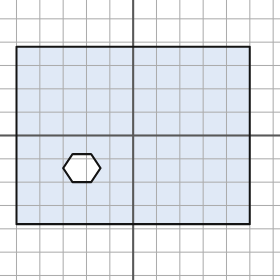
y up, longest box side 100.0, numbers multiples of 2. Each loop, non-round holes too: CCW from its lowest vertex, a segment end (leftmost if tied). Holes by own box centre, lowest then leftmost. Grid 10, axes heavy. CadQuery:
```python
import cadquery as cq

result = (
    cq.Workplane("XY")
    .moveTo(-50.0, -38.0)
    .lineTo(50.0, -38.0)
    .lineTo(50.0, 38.0)
    .lineTo(-50.0, 38.0)
    .close()
    .moveTo(-26.0, -20.0)
    .lineTo(-18.0, -20.0)
    .lineTo(-14.0, -14.0)
    .lineTo(-18.0, -8.0)
    .lineTo(-26.0, -8.0)
    .lineTo(-30.0, -14.0)
    .close()
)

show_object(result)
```